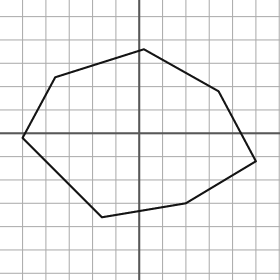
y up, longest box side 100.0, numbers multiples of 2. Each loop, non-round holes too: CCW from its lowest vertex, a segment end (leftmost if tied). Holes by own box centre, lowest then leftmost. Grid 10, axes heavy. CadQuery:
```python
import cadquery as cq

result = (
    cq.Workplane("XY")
    .moveTo(-16.0, -36.0)
    .lineTo(20.0, -30.0)
    .lineTo(50.0, -12.0)
    .lineTo(34.0, 18.0)
    .lineTo(2.0, 36.0)
    .lineTo(-36.0, 24.0)
    .lineTo(-50.0, -2.0)
    .close()
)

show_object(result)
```